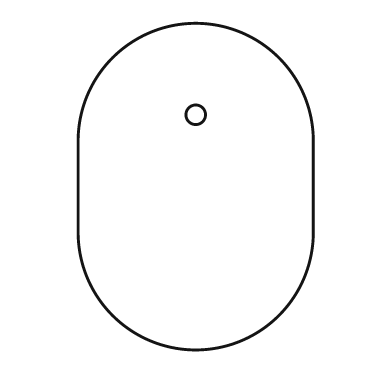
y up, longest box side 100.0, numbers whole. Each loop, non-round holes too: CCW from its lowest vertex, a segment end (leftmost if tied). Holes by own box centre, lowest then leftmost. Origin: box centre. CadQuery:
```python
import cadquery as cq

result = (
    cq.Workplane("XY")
    .moveTo(-36.0, -14.0)
    .threePointArc((0.0, -50.0), (36.0, -14.0))
    .lineTo(36.0, 14.0)
    .threePointArc((0.0, 50.0), (-36.0, 14.0))
    .close()
    .moveTo(0.0, 22.0)
    .circle(3.0)
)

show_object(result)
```